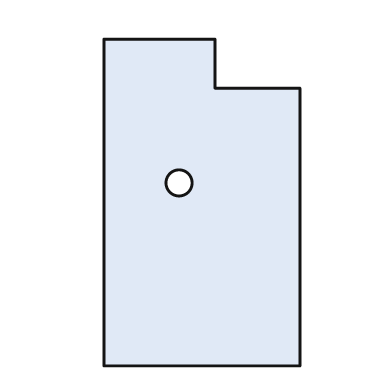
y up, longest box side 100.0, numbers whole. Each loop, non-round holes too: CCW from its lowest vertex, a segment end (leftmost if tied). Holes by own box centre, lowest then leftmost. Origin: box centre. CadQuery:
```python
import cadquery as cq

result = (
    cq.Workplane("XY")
    .moveTo(-30.0, -50.0)
    .lineTo(30.0, -50.0)
    .lineTo(30.0, 35.0)
    .lineTo(4.0, 35.0)
    .lineTo(4.0, 50.0)
    .lineTo(-30.0, 50.0)
    .close()
    .moveTo(-7.0, 6.0)
    .circle(4.0)
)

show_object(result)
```